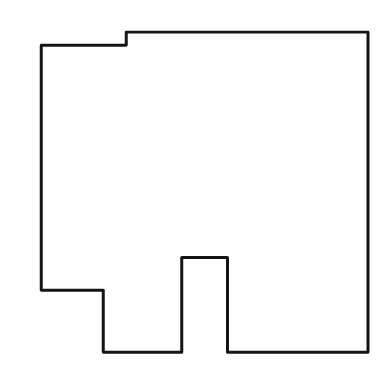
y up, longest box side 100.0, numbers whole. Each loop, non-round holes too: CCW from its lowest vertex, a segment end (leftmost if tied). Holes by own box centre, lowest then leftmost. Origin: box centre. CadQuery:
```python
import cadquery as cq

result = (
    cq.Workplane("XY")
    .moveTo(-31.0, -49.0)
    .lineTo(-7.0, -49.0)
    .lineTo(-7.0, -20.0)
    .lineTo(7.0, -20.0)
    .lineTo(7.0, -49.0)
    .lineTo(50.0, -49.0)
    .lineTo(50.0, 49.0)
    .lineTo(-24.0, 49.0)
    .lineTo(-24.0, 45.0)
    .lineTo(-50.0, 45.0)
    .lineTo(-50.0, -30.0)
    .lineTo(-31.0, -30.0)
    .close()
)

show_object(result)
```